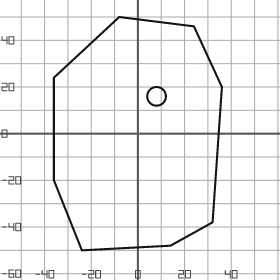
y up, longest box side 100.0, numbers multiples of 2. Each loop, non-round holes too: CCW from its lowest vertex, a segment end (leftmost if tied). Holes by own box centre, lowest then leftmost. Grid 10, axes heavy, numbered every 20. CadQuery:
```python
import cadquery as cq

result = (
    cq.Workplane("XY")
    .moveTo(-24.0, -50.0)
    .lineTo(14.0, -48.0)
    .lineTo(32.0, -38.0)
    .lineTo(36.0, 20.0)
    .lineTo(24.0, 46.0)
    .lineTo(-8.0, 50.0)
    .lineTo(-36.0, 24.0)
    .lineTo(-36.0, -20.0)
    .close()
    .moveTo(8.0, 16.0)
    .circle(4.0)
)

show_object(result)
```